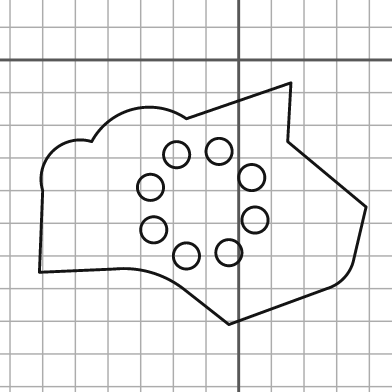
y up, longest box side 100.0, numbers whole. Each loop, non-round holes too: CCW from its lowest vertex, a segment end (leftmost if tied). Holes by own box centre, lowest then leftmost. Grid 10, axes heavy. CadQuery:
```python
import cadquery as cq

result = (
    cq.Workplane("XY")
    .moveTo(-3.0, -81.0)
    .lineTo(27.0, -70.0)
    .threePointArc((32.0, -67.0), (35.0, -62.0))
    .lineTo(39.0, -45.0)
    .lineTo(15.0, -25.0)
    .lineTo(16.0, -7.0)
    .lineTo(-16.0, -18.0)
    .threePointArc((-32.0, -15.0), (-45.0, -25.0))
    .threePointArc((-57.0, -28.0), (-60.0, -40.0))
    .lineTo(-61.0, -65.0)
    .lineTo(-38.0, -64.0)
    .threePointArc((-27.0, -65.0), (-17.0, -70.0))
    .close()
    .moveTo(-16.0, -60.0)
    .circle(4.0)
    .moveTo(-3.0, -59.0)
    .circle(4.0)
    .moveTo(-26.0, -52.0)
    .circle(4.0)
    .moveTo(5.0, -49.0)
    .circle(4.0)
    .moveTo(-27.0, -39.0)
    .circle(4.0)
    .moveTo(4.0, -36.0)
    .circle(4.0)
    .moveTo(-19.0, -29.0)
    .circle(4.0)
    .moveTo(-6.0, -28.0)
    .circle(4.0)
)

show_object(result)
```